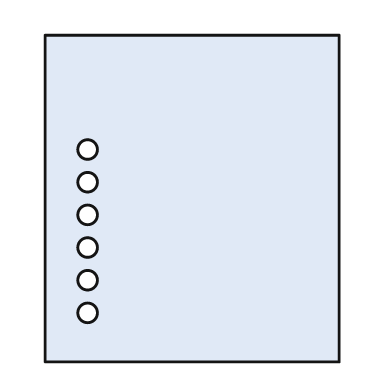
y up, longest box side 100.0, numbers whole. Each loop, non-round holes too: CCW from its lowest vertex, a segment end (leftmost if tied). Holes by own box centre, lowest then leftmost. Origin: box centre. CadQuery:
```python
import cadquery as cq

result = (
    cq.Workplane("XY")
    .moveTo(-45.0, -50.0)
    .lineTo(45.0, -50.0)
    .lineTo(45.0, 50.0)
    .lineTo(-45.0, 50.0)
    .close()
    .moveTo(-32.0, -35.0)
    .circle(3.0)
    .moveTo(-32.0, -25.0)
    .circle(3.0)
    .moveTo(-32.0, -15.0)
    .circle(3.0)
    .moveTo(-32.0, -5.0)
    .circle(3.0)
    .moveTo(-32.0, 5.0)
    .circle(3.0)
    .moveTo(-32.0, 15.0)
    .circle(3.0)
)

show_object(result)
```